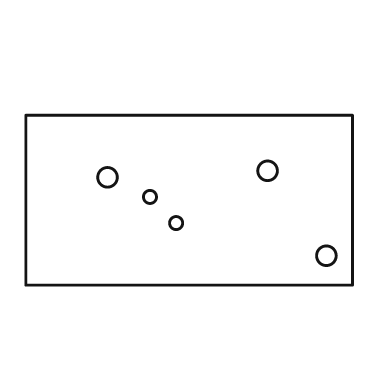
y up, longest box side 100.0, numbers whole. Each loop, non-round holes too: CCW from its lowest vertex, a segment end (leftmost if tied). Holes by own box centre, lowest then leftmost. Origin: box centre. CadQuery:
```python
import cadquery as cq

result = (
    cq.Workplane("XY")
    .moveTo(-50.0, -26.0)
    .lineTo(50.0, -26.0)
    .lineTo(50.0, 26.0)
    .lineTo(-50.0, 26.0)
    .close()
    .moveTo(42.0, -17.0)
    .circle(3.0)
    .moveTo(-4.0, -7.0)
    .circle(2.0)
    .moveTo(-12.0, 1.0)
    .circle(2.0)
    .moveTo(-25.0, 7.0)
    .circle(3.0)
    .moveTo(24.0, 9.0)
    .circle(3.0)
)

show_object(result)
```